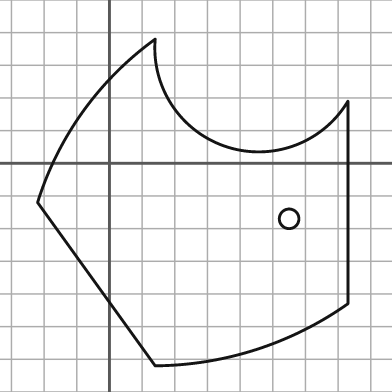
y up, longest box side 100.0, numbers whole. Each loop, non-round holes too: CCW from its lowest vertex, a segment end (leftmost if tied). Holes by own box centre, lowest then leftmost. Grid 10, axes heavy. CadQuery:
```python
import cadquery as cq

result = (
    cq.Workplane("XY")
    .moveTo(14.0, -62.0)
    .threePointArc((45.0, -57.0), (73.0, -43.0))
    .lineTo(73.0, 19.0)
    .threePointArc((36.0, 5.0), (14.0, 38.0))
    .threePointArc((-8.0, 16.0), (-22.0, -12.0))
    .close()
    .moveTo(55.0, -17.0)
    .circle(3.0)
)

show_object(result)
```